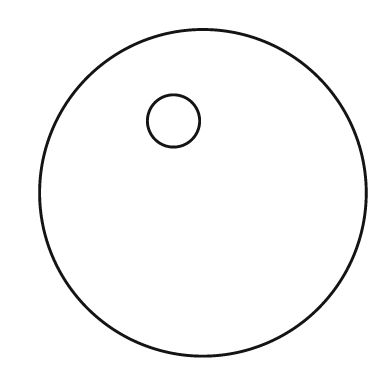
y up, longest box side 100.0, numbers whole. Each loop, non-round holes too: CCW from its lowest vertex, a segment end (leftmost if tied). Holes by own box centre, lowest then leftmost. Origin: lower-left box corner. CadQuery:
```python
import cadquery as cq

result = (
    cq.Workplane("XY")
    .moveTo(50.0, 50.0)
    .circle(50.0)
    .moveTo(41.0, 72.0)
    .circle(8.0)
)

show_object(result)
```